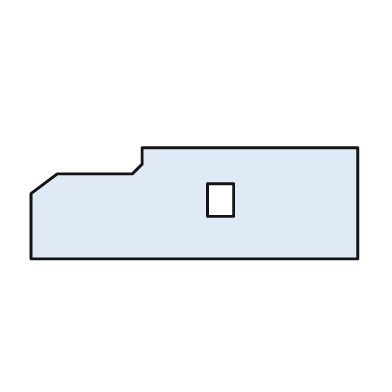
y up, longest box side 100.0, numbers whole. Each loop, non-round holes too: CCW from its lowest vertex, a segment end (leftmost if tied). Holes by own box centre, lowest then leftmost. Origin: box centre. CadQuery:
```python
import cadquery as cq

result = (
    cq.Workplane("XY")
    .moveTo(-50.0, -17.0)
    .lineTo(50.0, -17.0)
    .lineTo(50.0, 17.0)
    .lineTo(-16.0, 17.0)
    .lineTo(-16.0, 12.0)
    .lineTo(-19.0, 9.0)
    .lineTo(-42.0, 9.0)
    .lineTo(-50.0, 3.0)
    .close()
    .moveTo(4.0, -4.0)
    .lineTo(12.0, -4.0)
    .lineTo(12.0, 6.0)
    .lineTo(4.0, 6.0)
    .close()
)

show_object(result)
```